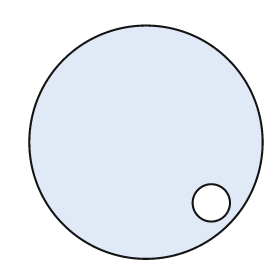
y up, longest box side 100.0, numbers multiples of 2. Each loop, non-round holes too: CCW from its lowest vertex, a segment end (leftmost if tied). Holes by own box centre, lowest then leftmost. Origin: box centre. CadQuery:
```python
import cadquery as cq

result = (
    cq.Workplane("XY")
    .moveTo(0.0, 0.0)
    .circle(50.0)
    .moveTo(28.0, -26.0)
    .circle(8.0)
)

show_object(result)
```